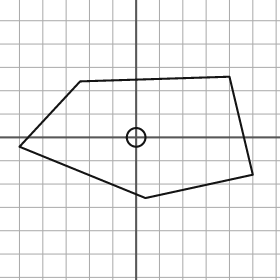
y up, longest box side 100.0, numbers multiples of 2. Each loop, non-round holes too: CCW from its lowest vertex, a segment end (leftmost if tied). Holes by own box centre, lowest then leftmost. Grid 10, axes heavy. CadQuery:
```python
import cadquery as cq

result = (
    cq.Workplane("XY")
    .moveTo(4.0, -26.0)
    .lineTo(50.0, -16.0)
    .lineTo(40.0, 26.0)
    .lineTo(-24.0, 24.0)
    .lineTo(-50.0, -4.0)
    .close()
    .moveTo(0.0, 0.0)
    .circle(4.0)
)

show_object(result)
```